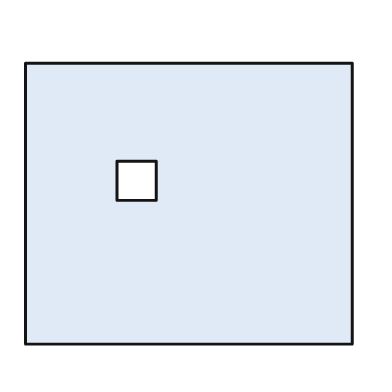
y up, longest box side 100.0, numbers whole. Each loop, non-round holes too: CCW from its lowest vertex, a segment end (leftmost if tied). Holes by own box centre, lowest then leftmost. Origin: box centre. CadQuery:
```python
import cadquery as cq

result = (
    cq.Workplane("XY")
    .moveTo(-50.0, -43.0)
    .lineTo(50.0, -43.0)
    .lineTo(50.0, 43.0)
    .lineTo(-50.0, 43.0)
    .close()
    .moveTo(-22.0, 1.0)
    .lineTo(-10.0, 1.0)
    .lineTo(-10.0, 13.0)
    .lineTo(-22.0, 13.0)
    .close()
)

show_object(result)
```